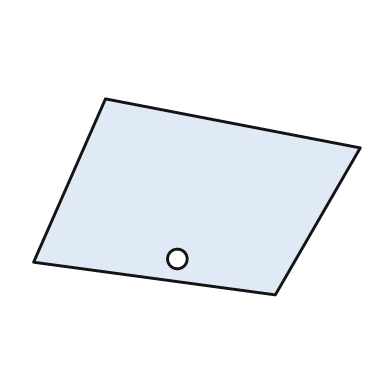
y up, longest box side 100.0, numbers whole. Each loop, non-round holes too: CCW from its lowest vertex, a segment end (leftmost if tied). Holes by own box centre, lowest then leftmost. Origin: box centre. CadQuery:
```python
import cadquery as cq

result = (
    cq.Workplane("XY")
    .moveTo(24.0, -30.0)
    .lineTo(50.0, 15.0)
    .lineTo(-28.0, 30.0)
    .lineTo(-50.0, -20.0)
    .close()
    .moveTo(-6.0, -19.0)
    .circle(3.0)
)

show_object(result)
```